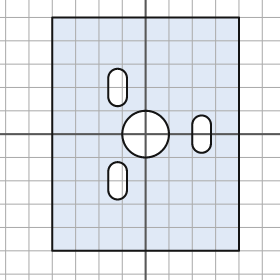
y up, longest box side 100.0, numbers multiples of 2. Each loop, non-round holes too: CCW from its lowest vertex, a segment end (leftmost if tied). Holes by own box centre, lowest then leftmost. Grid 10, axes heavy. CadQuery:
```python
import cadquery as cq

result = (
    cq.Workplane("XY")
    .moveTo(-40.0, -50.0)
    .lineTo(40.0, -50.0)
    .lineTo(40.0, 50.0)
    .lineTo(-40.0, 50.0)
    .close()
    .moveTo(-16.0, -24.0)
    .threePointArc((-12.0, -28.0), (-8.0, -24.0))
    .lineTo(-8.0, -16.0)
    .threePointArc((-12.0, -12.0), (-16.0, -16.0))
    .close()
    .moveTo(0.0, 0.0)
    .circle(10.0)
    .moveTo(20.0, -4.0)
    .threePointArc((24.0, -8.0), (28.0, -4.0))
    .lineTo(28.0, 4.0)
    .threePointArc((24.0, 8.0), (20.0, 4.0))
    .close()
    .moveTo(-16.0, 16.0)
    .threePointArc((-12.0, 12.0), (-8.0, 16.0))
    .lineTo(-8.0, 24.0)
    .threePointArc((-12.0, 28.0), (-16.0, 24.0))
    .close()
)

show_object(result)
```